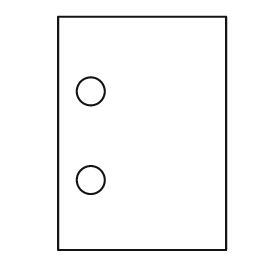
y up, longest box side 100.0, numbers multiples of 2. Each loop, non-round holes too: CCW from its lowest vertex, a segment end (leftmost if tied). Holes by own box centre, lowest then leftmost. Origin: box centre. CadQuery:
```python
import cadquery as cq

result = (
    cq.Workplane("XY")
    .moveTo(-36.0, -50.0)
    .lineTo(36.0, -50.0)
    .lineTo(36.0, 50.0)
    .lineTo(-36.0, 50.0)
    .close()
    .moveTo(-22.0, -20.0)
    .circle(6.0)
    .moveTo(-22.0, 18.0)
    .circle(6.0)
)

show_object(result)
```